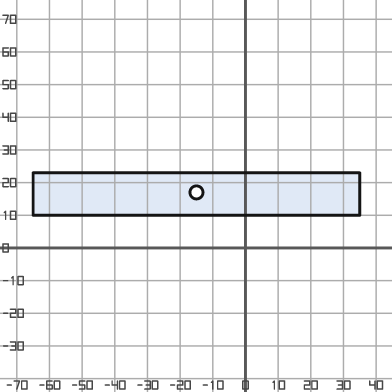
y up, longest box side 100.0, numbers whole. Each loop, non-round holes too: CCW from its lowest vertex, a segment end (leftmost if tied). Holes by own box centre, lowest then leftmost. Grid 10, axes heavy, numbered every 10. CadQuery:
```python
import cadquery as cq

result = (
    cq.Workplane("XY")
    .moveTo(-65.0, 10.0)
    .lineTo(35.0, 10.0)
    .lineTo(35.0, 23.0)
    .lineTo(-65.0, 23.0)
    .close()
    .moveTo(-15.0, 17.0)
    .circle(2.0)
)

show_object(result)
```